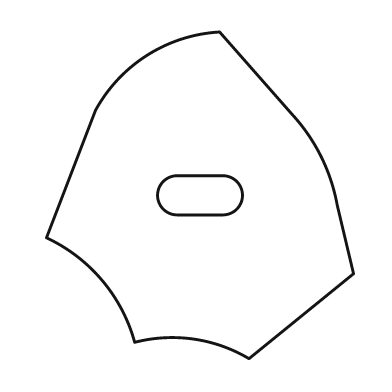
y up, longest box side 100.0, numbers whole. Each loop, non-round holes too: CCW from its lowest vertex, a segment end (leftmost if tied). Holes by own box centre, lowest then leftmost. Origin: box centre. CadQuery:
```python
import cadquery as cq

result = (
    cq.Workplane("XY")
    .moveTo(15.0, -50.0)
    .lineTo(47.0, -24.0)
    .lineTo(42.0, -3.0)
    .threePointArc((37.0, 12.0), (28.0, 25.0))
    .lineTo(6.0, 50.0)
    .threePointArc((-16.0, 43.0), (-32.0, 26.0))
    .lineTo(-47.0, -13.0)
    .threePointArc((-30.0, -26.0), (-20.0, -45.0))
    .threePointArc((-2.0, -44.0), (15.0, -50.0))
    .close()
    .moveTo(-7.0, -6.0)
    .lineTo(7.0, -6.0)
    .threePointArc((13.0, 0.0), (7.0, 6.0))
    .lineTo(-7.0, 6.0)
    .threePointArc((-13.0, 0.0), (-7.0, -6.0))
    .close()
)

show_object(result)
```